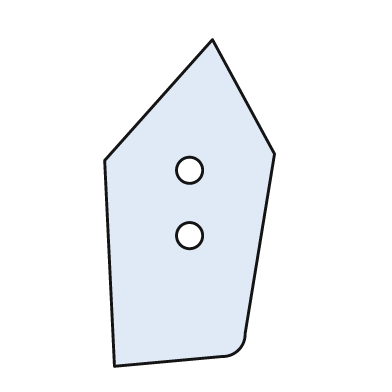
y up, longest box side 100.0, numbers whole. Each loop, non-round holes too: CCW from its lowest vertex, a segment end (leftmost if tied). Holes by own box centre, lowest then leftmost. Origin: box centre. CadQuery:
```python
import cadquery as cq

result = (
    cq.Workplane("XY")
    .moveTo(-23.0, -50.0)
    .lineTo(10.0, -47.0)
    .threePointArc((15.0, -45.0), (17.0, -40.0))
    .lineTo(26.0, 15.0)
    .lineTo(7.0, 50.0)
    .lineTo(-26.0, 13.0)
    .close()
    .moveTo(0.0, -10.0)
    .circle(4.0)
    .moveTo(0.0, 10.0)
    .circle(4.0)
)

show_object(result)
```